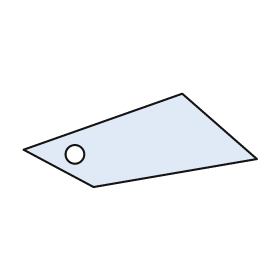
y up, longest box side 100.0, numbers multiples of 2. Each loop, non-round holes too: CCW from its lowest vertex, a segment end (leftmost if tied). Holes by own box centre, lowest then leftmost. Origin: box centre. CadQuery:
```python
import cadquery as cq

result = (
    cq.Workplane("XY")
    .moveTo(-20.0, -20.0)
    .lineTo(50.0, -8.0)
    .lineTo(18.0, 20.0)
    .lineTo(-50.0, -4.0)
    .close()
    .moveTo(-28.0, -6.0)
    .circle(4.0)
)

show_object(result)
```